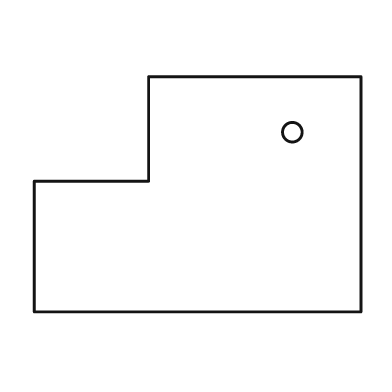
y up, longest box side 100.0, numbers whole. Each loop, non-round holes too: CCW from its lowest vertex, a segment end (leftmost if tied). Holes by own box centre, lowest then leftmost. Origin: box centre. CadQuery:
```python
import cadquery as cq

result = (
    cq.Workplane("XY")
    .moveTo(-50.0, -36.0)
    .lineTo(50.0, -36.0)
    .lineTo(50.0, 36.0)
    .lineTo(-15.0, 36.0)
    .lineTo(-15.0, 4.0)
    .lineTo(-50.0, 4.0)
    .close()
    .moveTo(29.0, 19.0)
    .circle(3.0)
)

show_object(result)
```